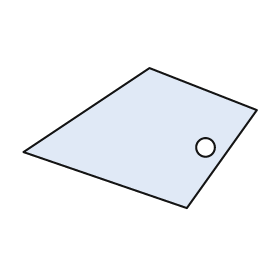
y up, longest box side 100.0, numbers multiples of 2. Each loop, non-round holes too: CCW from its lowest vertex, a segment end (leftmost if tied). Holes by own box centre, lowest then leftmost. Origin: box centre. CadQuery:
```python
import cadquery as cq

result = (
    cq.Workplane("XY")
    .moveTo(20.0, -30.0)
    .lineTo(50.0, 12.0)
    .lineTo(4.0, 30.0)
    .lineTo(-50.0, -6.0)
    .close()
    .moveTo(28.0, -4.0)
    .circle(4.0)
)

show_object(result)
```